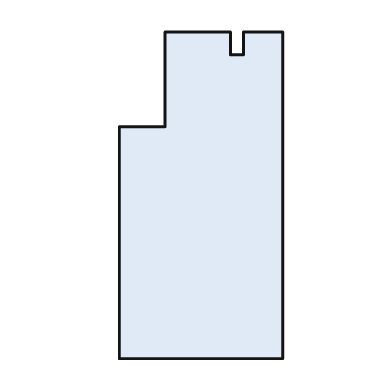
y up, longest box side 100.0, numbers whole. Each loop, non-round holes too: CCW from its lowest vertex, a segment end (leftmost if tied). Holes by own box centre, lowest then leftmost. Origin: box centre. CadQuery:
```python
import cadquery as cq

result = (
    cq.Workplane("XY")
    .moveTo(-25.0, -50.0)
    .lineTo(25.0, -50.0)
    .lineTo(25.0, 50.0)
    .lineTo(13.0, 50.0)
    .lineTo(13.0, 43.0)
    .lineTo(9.0, 43.0)
    .lineTo(9.0, 50.0)
    .lineTo(-11.0, 50.0)
    .lineTo(-11.0, 21.0)
    .lineTo(-25.0, 21.0)
    .close()
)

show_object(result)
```